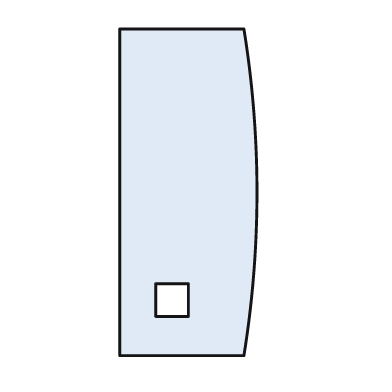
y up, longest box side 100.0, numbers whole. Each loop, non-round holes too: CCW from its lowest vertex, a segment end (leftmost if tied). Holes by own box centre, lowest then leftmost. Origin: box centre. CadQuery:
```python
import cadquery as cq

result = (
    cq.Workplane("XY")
    .moveTo(-21.0, -50.0)
    .lineTo(17.0, -50.0)
    .threePointArc((21.0, 0.0), (17.0, 50.0))
    .lineTo(-21.0, 50.0)
    .close()
    .moveTo(-10.0, -38.0)
    .lineTo(0.0, -38.0)
    .lineTo(0.0, -28.0)
    .lineTo(-10.0, -28.0)
    .close()
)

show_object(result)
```